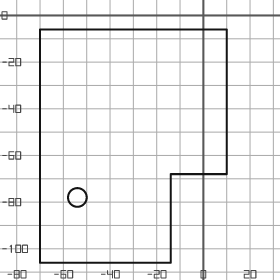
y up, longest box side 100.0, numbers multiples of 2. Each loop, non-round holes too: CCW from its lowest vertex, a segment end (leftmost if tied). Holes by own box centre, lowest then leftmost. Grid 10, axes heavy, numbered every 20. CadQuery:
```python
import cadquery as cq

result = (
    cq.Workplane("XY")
    .moveTo(-70.0, -106.0)
    .lineTo(-14.0, -106.0)
    .lineTo(-14.0, -68.0)
    .lineTo(10.0, -68.0)
    .lineTo(10.0, -6.0)
    .lineTo(-70.0, -6.0)
    .close()
    .moveTo(-54.0, -78.0)
    .circle(4.0)
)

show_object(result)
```